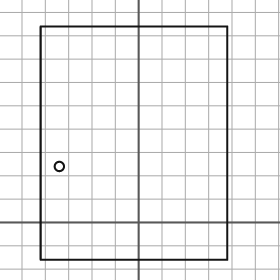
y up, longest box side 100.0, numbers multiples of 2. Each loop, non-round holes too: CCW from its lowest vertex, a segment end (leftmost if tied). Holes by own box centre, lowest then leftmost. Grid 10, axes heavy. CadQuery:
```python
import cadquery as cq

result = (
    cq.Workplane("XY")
    .moveTo(-42.0, -16.0)
    .lineTo(38.0, -16.0)
    .lineTo(38.0, 84.0)
    .lineTo(-42.0, 84.0)
    .close()
    .moveTo(-34.0, 24.0)
    .circle(2.0)
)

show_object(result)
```